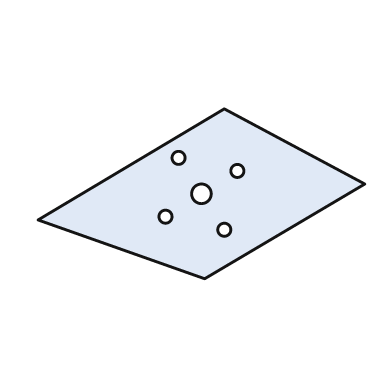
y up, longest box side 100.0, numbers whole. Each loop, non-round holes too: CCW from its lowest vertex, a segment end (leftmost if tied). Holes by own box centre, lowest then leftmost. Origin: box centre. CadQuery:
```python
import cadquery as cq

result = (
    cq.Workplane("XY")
    .moveTo(1.0, -26.0)
    .lineTo(50.0, 3.0)
    .lineTo(7.0, 26.0)
    .lineTo(-50.0, -8.0)
    .close()
    .moveTo(7.0, -11.0)
    .circle(2.0)
    .moveTo(-11.0, -7.0)
    .circle(2.0)
    .moveTo(0.0, 0.0)
    .circle(3.0)
    .moveTo(11.0, 7.0)
    .circle(2.0)
    .moveTo(-7.0, 11.0)
    .circle(2.0)
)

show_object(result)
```